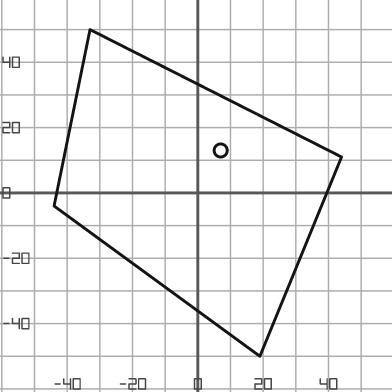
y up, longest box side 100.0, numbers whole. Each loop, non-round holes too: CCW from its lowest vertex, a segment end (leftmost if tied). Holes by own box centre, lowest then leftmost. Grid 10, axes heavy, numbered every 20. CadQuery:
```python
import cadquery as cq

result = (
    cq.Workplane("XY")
    .moveTo(19.0, -50.0)
    .lineTo(44.0, 11.0)
    .lineTo(-33.0, 50.0)
    .lineTo(-44.0, -4.0)
    .close()
    .moveTo(7.0, 13.0)
    .circle(2.0)
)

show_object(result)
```